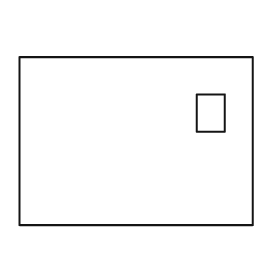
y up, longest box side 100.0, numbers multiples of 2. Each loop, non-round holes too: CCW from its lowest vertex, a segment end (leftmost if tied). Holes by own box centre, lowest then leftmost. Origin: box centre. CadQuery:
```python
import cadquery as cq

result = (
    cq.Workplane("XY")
    .moveTo(-50.0, -36.0)
    .lineTo(50.0, -36.0)
    .lineTo(50.0, 36.0)
    .lineTo(-50.0, 36.0)
    .close()
    .moveTo(26.0, 4.0)
    .lineTo(38.0, 4.0)
    .lineTo(38.0, 20.0)
    .lineTo(26.0, 20.0)
    .close()
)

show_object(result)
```